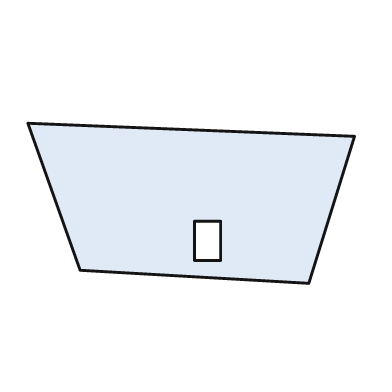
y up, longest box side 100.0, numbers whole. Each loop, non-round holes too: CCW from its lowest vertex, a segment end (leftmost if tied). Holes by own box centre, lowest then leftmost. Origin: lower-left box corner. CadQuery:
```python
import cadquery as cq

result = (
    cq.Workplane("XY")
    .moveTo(86.0, 0.0)
    .lineTo(100.0, 45.0)
    .lineTo(0.0, 49.0)
    .lineTo(16.0, 4.0)
    .close()
    .moveTo(51.0, 7.0)
    .lineTo(59.0, 7.0)
    .lineTo(59.0, 19.0)
    .lineTo(51.0, 19.0)
    .close()
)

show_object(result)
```